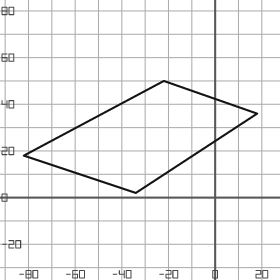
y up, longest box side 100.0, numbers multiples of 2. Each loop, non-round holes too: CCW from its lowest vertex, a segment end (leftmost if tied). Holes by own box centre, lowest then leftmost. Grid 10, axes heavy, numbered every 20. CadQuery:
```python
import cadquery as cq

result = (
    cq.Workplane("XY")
    .moveTo(-34.0, 2.0)
    .lineTo(18.0, 36.0)
    .lineTo(-22.0, 50.0)
    .lineTo(-82.0, 18.0)
    .close()
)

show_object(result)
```